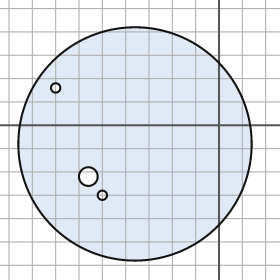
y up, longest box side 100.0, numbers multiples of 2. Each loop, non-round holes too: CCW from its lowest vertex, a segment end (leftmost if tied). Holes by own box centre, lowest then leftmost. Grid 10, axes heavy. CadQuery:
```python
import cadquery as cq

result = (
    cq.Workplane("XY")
    .moveTo(-36.0, -8.0)
    .circle(50.0)
    .moveTo(-50.0, -30.0)
    .circle(2.0)
    .moveTo(-56.0, -22.0)
    .circle(4.0)
    .moveTo(-70.0, 16.0)
    .circle(2.0)
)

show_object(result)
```